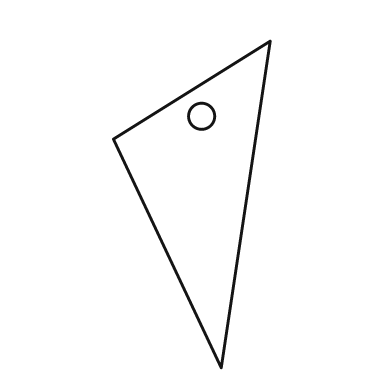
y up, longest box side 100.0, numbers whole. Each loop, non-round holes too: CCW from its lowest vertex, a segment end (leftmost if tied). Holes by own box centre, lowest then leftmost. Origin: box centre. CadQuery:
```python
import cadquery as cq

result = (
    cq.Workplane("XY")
    .moveTo(9.0, -50.0)
    .lineTo(24.0, 50.0)
    .lineTo(-24.0, 20.0)
    .close()
    .moveTo(3.0, 27.0)
    .circle(4.0)
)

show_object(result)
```